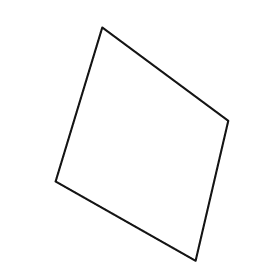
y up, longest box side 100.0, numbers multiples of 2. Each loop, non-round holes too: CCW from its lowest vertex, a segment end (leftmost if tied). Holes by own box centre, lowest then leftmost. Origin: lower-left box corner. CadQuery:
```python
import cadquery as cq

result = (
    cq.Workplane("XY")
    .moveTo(60.0, 0.0)
    .lineTo(74.0, 60.0)
    .lineTo(20.0, 100.0)
    .lineTo(0.0, 34.0)
    .close()
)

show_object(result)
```